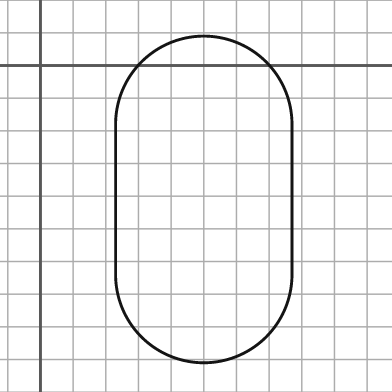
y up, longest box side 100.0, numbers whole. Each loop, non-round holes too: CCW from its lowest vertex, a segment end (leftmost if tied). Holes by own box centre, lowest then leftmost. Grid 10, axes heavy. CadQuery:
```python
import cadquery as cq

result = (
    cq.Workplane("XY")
    .moveTo(23.0, -64.0)
    .threePointArc((50.0, -91.0), (77.0, -64.0))
    .lineTo(77.0, -18.0)
    .threePointArc((50.0, 9.0), (23.0, -18.0))
    .close()
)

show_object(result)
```